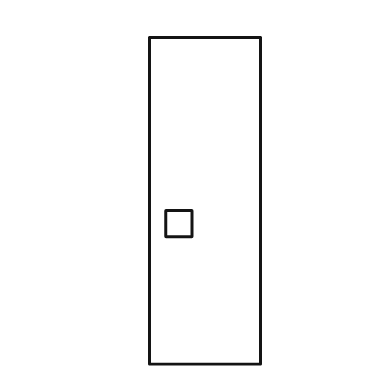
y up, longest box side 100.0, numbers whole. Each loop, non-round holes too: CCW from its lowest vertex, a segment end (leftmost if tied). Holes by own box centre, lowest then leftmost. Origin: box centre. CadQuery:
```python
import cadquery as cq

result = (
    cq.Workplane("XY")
    .moveTo(-17.0, -50.0)
    .lineTo(17.0, -50.0)
    .lineTo(17.0, 50.0)
    .lineTo(-17.0, 50.0)
    .close()
    .moveTo(-12.0, -11.0)
    .lineTo(-4.0, -11.0)
    .lineTo(-4.0, -3.0)
    .lineTo(-12.0, -3.0)
    .close()
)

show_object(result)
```